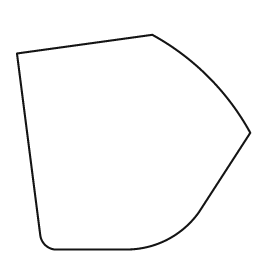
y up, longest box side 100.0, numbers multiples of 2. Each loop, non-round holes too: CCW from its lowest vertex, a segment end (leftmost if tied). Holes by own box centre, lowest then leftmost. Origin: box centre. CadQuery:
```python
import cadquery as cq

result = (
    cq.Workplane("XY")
    .moveTo(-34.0, -46.0)
    .lineTo(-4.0, -46.0)
    .threePointArc((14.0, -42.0), (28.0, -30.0))
    .lineTo(50.0, 4.0)
    .threePointArc((32.0, 28.0), (8.0, 46.0))
    .lineTo(-50.0, 38.0)
    .lineTo(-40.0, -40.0)
    .threePointArc((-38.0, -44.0), (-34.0, -46.0))
    .close()
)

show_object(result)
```